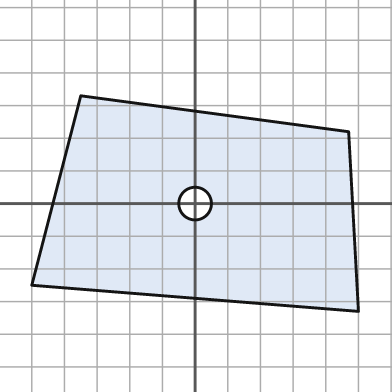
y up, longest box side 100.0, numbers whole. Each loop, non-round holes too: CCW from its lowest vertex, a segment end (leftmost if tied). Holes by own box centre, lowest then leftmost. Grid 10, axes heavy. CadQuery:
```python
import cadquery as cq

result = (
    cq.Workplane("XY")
    .moveTo(50.0, -33.0)
    .lineTo(47.0, 22.0)
    .lineTo(-35.0, 33.0)
    .lineTo(-50.0, -25.0)
    .close()
    .moveTo(0.0, 0.0)
    .circle(5.0)
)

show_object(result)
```